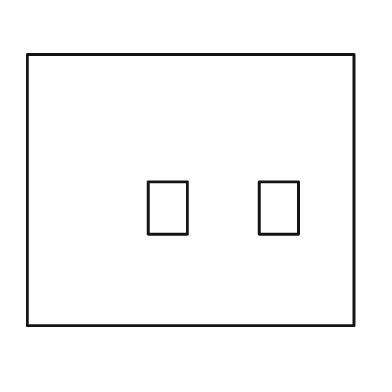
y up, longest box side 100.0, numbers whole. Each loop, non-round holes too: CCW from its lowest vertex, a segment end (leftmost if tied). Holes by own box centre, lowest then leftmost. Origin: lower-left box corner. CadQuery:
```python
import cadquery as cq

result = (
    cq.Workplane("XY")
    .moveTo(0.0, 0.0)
    .lineTo(100.0, 0.0)
    .lineTo(100.0, 83.0)
    .lineTo(0.0, 83.0)
    .close()
    .moveTo(37.0, 28.0)
    .lineTo(49.0, 28.0)
    .lineTo(49.0, 44.0)
    .lineTo(37.0, 44.0)
    .close()
    .moveTo(71.0, 28.0)
    .lineTo(83.0, 28.0)
    .lineTo(83.0, 44.0)
    .lineTo(71.0, 44.0)
    .close()
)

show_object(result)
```